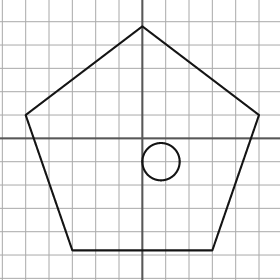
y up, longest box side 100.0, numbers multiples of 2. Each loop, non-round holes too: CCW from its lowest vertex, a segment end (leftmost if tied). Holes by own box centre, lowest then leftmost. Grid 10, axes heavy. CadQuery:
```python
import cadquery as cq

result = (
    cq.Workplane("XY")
    .moveTo(-30.0, -48.0)
    .lineTo(30.0, -48.0)
    .lineTo(50.0, 10.0)
    .lineTo(0.0, 48.0)
    .lineTo(-50.0, 10.0)
    .close()
    .moveTo(8.0, -10.0)
    .circle(8.0)
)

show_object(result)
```